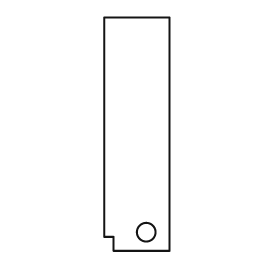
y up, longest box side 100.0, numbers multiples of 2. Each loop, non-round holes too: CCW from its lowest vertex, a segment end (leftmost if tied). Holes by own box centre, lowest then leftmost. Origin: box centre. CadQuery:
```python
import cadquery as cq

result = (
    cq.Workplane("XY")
    .moveTo(-10.0, -50.0)
    .lineTo(14.0, -50.0)
    .lineTo(14.0, 50.0)
    .lineTo(-14.0, 50.0)
    .lineTo(-14.0, -44.0)
    .lineTo(-10.0, -44.0)
    .close()
    .moveTo(4.0, -42.0)
    .circle(4.0)
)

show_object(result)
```